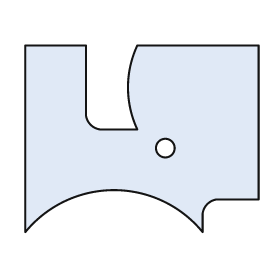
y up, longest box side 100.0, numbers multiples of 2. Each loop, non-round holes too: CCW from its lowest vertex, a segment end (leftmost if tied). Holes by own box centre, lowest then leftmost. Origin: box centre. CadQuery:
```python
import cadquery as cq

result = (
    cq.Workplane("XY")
    .moveTo(-50.0, -40.0)
    .threePointArc((-12.0, -22.0), (26.0, -40.0))
    .lineTo(26.0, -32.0)
    .threePointArc((28.0, -28.0), (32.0, -26.0))
    .lineTo(50.0, -26.0)
    .lineTo(50.0, 40.0)
    .lineTo(-2.0, 40.0)
    .threePointArc((-6.0, 22.0), (-2.0, 4.0))
    .lineTo(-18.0, 4.0)
    .threePointArc((-22.0, 6.0), (-24.0, 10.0))
    .lineTo(-24.0, 40.0)
    .lineTo(-50.0, 40.0)
    .close()
    .moveTo(10.0, -4.0)
    .circle(4.0)
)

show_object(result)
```